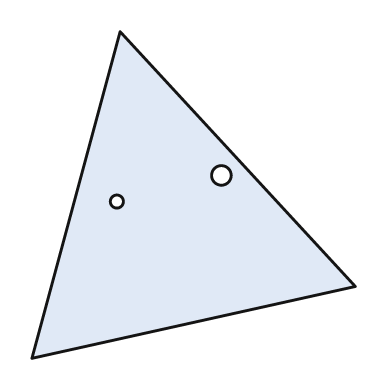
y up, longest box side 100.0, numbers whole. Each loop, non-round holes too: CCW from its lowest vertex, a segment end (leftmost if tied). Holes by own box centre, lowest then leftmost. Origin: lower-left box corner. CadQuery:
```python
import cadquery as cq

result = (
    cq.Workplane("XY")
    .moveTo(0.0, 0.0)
    .lineTo(99.0, 22.0)
    .lineTo(27.0, 100.0)
    .close()
    .moveTo(26.0, 48.0)
    .circle(2.0)
    .moveTo(58.0, 56.0)
    .circle(3.0)
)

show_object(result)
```